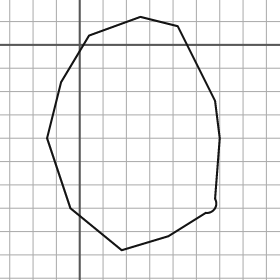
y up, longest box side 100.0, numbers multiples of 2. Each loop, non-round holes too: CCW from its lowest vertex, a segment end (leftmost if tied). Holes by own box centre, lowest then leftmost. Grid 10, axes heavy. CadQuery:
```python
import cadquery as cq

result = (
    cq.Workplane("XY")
    .moveTo(18.0, -88.0)
    .lineTo(38.0, -82.0)
    .lineTo(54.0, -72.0)
    .threePointArc((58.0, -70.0), (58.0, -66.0))
    .lineTo(60.0, -40.0)
    .lineTo(58.0, -24.0)
    .lineTo(42.0, 8.0)
    .lineTo(26.0, 12.0)
    .lineTo(4.0, 4.0)
    .lineTo(-8.0, -16.0)
    .lineTo(-14.0, -40.0)
    .lineTo(-4.0, -70.0)
    .close()
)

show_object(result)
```